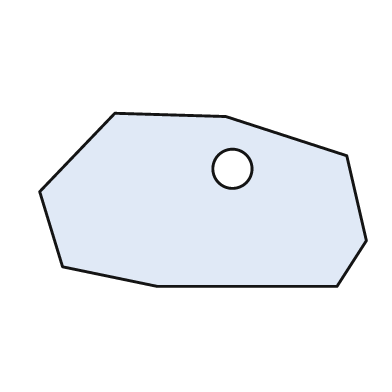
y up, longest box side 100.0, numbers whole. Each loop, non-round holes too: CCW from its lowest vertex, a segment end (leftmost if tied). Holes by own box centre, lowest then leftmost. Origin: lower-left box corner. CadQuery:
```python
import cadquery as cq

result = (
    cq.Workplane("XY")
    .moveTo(36.0, 0.0)
    .lineTo(91.0, 0.0)
    .lineTo(100.0, 14.0)
    .lineTo(94.0, 40.0)
    .lineTo(57.0, 52.0)
    .lineTo(23.0, 53.0)
    .lineTo(0.0, 29.0)
    .lineTo(7.0, 6.0)
    .close()
    .moveTo(59.0, 36.0)
    .circle(6.0)
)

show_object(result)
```